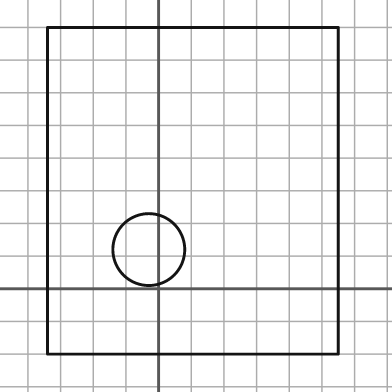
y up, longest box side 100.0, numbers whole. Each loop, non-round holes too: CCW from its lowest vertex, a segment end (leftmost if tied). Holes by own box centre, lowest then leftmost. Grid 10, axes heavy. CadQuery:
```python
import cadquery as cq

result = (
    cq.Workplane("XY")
    .moveTo(-34.0, -20.0)
    .lineTo(55.0, -20.0)
    .lineTo(55.0, 80.0)
    .lineTo(-34.0, 80.0)
    .close()
    .moveTo(-3.0, 12.0)
    .circle(11.0)
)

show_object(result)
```